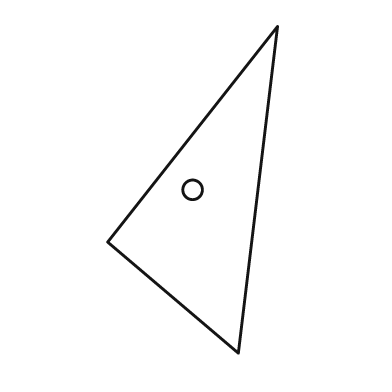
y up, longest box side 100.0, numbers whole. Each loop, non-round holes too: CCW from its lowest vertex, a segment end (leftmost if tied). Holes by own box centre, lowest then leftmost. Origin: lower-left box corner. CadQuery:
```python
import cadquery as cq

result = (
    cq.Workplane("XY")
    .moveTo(40.0, 0.0)
    .lineTo(52.0, 100.0)
    .lineTo(0.0, 34.0)
    .close()
    .moveTo(26.0, 50.0)
    .circle(3.0)
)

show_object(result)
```